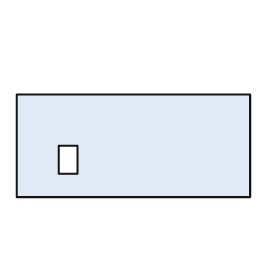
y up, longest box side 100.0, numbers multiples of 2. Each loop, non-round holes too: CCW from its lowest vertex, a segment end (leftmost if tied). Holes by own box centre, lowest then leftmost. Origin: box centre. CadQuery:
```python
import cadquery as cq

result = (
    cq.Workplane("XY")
    .moveTo(-50.0, -22.0)
    .lineTo(50.0, -22.0)
    .lineTo(50.0, 22.0)
    .lineTo(-50.0, 22.0)
    .close()
    .moveTo(-32.0, -12.0)
    .lineTo(-24.0, -12.0)
    .lineTo(-24.0, 0.0)
    .lineTo(-32.0, 0.0)
    .close()
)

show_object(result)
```